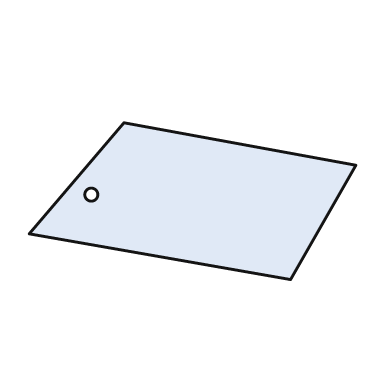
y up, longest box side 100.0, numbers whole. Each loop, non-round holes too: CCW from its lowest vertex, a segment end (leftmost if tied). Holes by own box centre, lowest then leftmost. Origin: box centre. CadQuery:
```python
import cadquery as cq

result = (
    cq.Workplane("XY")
    .moveTo(30.0, -24.0)
    .lineTo(50.0, 11.0)
    .lineTo(-21.0, 24.0)
    .lineTo(-50.0, -10.0)
    .close()
    .moveTo(-31.0, 2.0)
    .circle(2.0)
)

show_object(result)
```